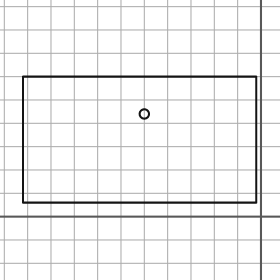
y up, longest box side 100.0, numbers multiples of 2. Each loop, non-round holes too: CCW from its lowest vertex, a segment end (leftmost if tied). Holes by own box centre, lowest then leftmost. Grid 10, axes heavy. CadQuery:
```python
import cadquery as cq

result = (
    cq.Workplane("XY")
    .moveTo(-102.0, 6.0)
    .lineTo(-2.0, 6.0)
    .lineTo(-2.0, 60.0)
    .lineTo(-102.0, 60.0)
    .close()
    .moveTo(-50.0, 44.0)
    .circle(2.0)
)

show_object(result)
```